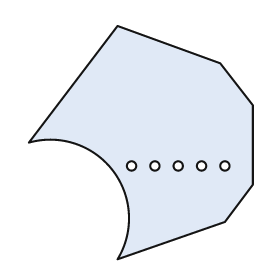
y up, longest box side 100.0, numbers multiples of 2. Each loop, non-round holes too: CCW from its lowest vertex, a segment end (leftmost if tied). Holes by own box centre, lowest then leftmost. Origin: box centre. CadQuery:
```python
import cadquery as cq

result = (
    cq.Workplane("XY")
    .moveTo(-10.0, -50.0)
    .lineTo(36.0, -34.0)
    .lineTo(48.0, -18.0)
    .lineTo(48.0, 16.0)
    .lineTo(34.0, 34.0)
    .lineTo(-10.0, 50.0)
    .lineTo(-48.0, 0.0)
    .threePointArc((-12.0, -12.0), (-10.0, -50.0))
    .close()
    .moveTo(-4.0, -10.0)
    .circle(2.0)
    .moveTo(6.0, -10.0)
    .circle(2.0)
    .moveTo(16.0, -10.0)
    .circle(2.0)
    .moveTo(26.0, -10.0)
    .circle(2.0)
    .moveTo(36.0, -10.0)
    .circle(2.0)
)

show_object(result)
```